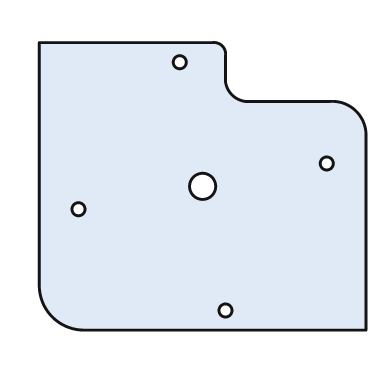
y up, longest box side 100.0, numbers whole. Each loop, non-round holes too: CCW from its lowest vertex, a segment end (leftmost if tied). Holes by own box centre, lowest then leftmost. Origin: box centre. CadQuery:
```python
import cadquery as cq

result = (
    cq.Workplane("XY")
    .moveTo(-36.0, -44.0)
    .lineTo(50.0, -44.0)
    .lineTo(50.0, 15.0)
    .threePointArc((47.0, 23.0), (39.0, 26.0))
    .lineTo(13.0, 26.0)
    .threePointArc((9.0, 28.0), (7.0, 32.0))
    .lineTo(7.0, 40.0)
    .threePointArc((6.0, 43.0), (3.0, 44.0))
    .lineTo(-50.0, 44.0)
    .lineTo(-50.0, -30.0)
    .threePointArc((-46.0, -40.0), (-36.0, -44.0))
    .close()
    .moveTo(7.0, -38.0)
    .circle(2.0)
    .moveTo(-38.0, -7.0)
    .circle(2.0)
    .moveTo(0.0, 0.0)
    .circle(4.0)
    .moveTo(38.0, 7.0)
    .circle(2.0)
    .moveTo(-7.0, 38.0)
    .circle(2.0)
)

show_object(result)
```